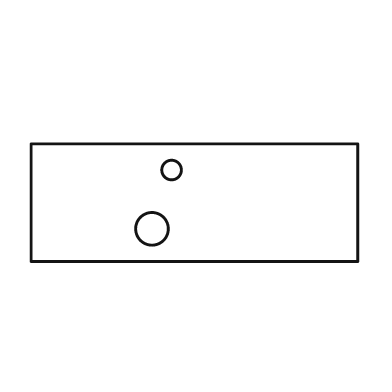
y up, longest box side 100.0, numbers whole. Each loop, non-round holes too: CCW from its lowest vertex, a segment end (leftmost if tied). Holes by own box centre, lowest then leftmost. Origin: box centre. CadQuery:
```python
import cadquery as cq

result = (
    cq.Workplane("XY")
    .moveTo(-50.0, -18.0)
    .lineTo(50.0, -18.0)
    .lineTo(50.0, 18.0)
    .lineTo(-50.0, 18.0)
    .close()
    .moveTo(-13.0, -8.0)
    .circle(5.0)
    .moveTo(-7.0, 10.0)
    .circle(3.0)
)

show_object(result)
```